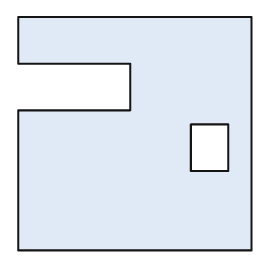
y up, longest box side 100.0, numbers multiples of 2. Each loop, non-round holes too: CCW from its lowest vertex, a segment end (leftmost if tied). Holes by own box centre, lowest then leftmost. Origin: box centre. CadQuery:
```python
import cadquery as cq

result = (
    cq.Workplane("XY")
    .moveTo(-50.0, -50.0)
    .lineTo(50.0, -50.0)
    .lineTo(50.0, 50.0)
    .lineTo(-50.0, 50.0)
    .lineTo(-50.0, 30.0)
    .lineTo(-2.0, 30.0)
    .lineTo(-2.0, 10.0)
    .lineTo(-50.0, 10.0)
    .close()
    .moveTo(24.0, -16.0)
    .lineTo(40.0, -16.0)
    .lineTo(40.0, 4.0)
    .lineTo(24.0, 4.0)
    .close()
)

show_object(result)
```